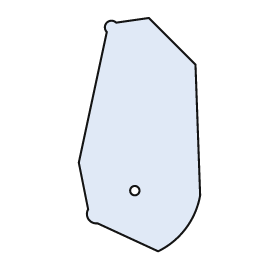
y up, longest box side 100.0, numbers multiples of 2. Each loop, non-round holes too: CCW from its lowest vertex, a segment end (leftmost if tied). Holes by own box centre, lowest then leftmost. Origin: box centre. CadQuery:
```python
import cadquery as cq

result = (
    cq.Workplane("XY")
    .moveTo(8.0, -50.0)
    .threePointArc((20.0, -40.0), (26.0, -26.0))
    .lineTo(24.0, 30.0)
    .lineTo(4.0, 50.0)
    .lineTo(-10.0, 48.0)
    .threePointArc((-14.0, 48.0), (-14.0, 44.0))
    .lineTo(-26.0, -12.0)
    .lineTo(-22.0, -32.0)
    .threePointArc((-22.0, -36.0), (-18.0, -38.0))
    .close()
    .moveTo(-2.0, -24.0)
    .circle(2.0)
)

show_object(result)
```